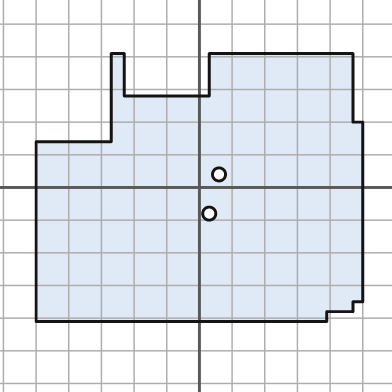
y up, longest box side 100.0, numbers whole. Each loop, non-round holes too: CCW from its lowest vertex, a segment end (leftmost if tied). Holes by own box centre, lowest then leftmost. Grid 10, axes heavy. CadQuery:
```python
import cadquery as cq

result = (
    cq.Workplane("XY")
    .moveTo(-50.0, -41.0)
    .lineTo(39.0, -41.0)
    .lineTo(39.0, -38.0)
    .lineTo(47.0, -38.0)
    .lineTo(47.0, -35.0)
    .lineTo(50.0, -35.0)
    .lineTo(50.0, 20.0)
    .lineTo(47.0, 20.0)
    .lineTo(47.0, 41.0)
    .lineTo(3.0, 41.0)
    .lineTo(3.0, 28.0)
    .lineTo(-23.0, 28.0)
    .lineTo(-23.0, 41.0)
    .lineTo(-27.0, 41.0)
    .lineTo(-27.0, 14.0)
    .lineTo(-50.0, 14.0)
    .close()
    .moveTo(3.0, -8.0)
    .circle(2.0)
    .moveTo(6.0, 4.0)
    .circle(2.0)
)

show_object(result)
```